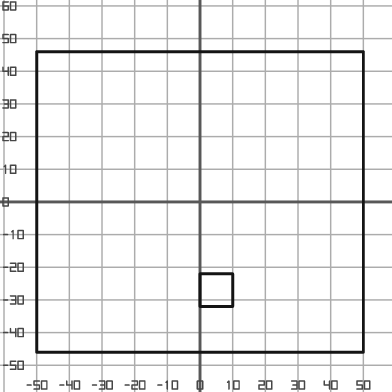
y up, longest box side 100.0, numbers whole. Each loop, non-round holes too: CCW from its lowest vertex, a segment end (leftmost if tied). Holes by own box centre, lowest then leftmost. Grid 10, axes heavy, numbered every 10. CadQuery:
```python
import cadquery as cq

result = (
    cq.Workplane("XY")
    .moveTo(-50.0, -46.0)
    .lineTo(50.0, -46.0)
    .lineTo(50.0, 46.0)
    .lineTo(-50.0, 46.0)
    .close()
    .moveTo(0.0, -32.0)
    .lineTo(10.0, -32.0)
    .lineTo(10.0, -22.0)
    .lineTo(0.0, -22.0)
    .close()
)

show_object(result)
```